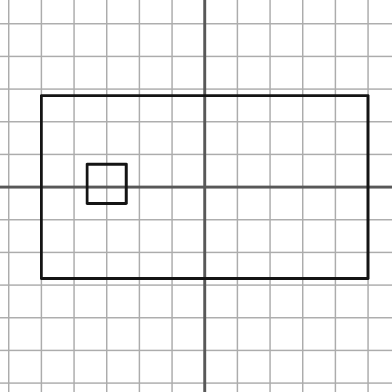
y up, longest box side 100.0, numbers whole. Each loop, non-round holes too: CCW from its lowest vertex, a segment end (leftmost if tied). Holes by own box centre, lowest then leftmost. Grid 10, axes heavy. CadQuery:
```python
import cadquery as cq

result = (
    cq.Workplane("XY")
    .moveTo(-50.0, -28.0)
    .lineTo(50.0, -28.0)
    .lineTo(50.0, 28.0)
    .lineTo(-50.0, 28.0)
    .close()
    .moveTo(-36.0, -5.0)
    .lineTo(-24.0, -5.0)
    .lineTo(-24.0, 7.0)
    .lineTo(-36.0, 7.0)
    .close()
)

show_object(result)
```